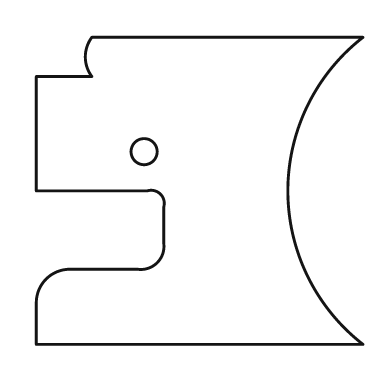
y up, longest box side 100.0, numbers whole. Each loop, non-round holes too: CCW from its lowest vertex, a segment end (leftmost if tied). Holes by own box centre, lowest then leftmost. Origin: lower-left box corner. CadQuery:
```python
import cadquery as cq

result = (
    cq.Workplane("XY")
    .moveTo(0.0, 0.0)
    .lineTo(100.0, 0.0)
    .threePointArc((77.0, 47.0), (100.0, 94.0))
    .lineTo(17.0, 94.0)
    .threePointArc((15.0, 88.0), (17.0, 82.0))
    .lineTo(0.0, 82.0)
    .lineTo(0.0, 47.0)
    .lineTo(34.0, 47.0)
    .threePointArc((38.0, 46.0), (39.0, 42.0))
    .lineTo(39.0, 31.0)
    .threePointArc((37.0, 25.0), (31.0, 23.0))
    .lineTo(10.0, 23.0)
    .threePointArc((3.0, 20.0), (0.0, 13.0))
    .close()
    .moveTo(33.0, 59.0)
    .circle(4.0)
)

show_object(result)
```